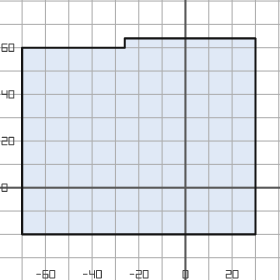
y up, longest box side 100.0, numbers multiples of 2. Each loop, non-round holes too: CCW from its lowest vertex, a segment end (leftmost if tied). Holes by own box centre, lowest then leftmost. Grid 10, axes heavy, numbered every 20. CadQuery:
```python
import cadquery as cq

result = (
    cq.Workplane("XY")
    .moveTo(-70.0, -20.0)
    .lineTo(30.0, -20.0)
    .lineTo(30.0, 64.0)
    .lineTo(-26.0, 64.0)
    .lineTo(-26.0, 60.0)
    .lineTo(-70.0, 60.0)
    .close()
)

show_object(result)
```